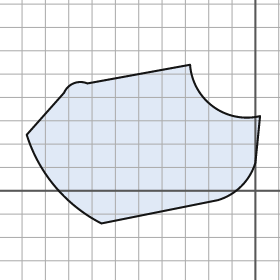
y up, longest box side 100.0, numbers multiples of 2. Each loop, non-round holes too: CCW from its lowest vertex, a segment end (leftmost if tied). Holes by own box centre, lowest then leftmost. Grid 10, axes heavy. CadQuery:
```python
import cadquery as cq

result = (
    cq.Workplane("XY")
    .moveTo(-66.0, -14.0)
    .lineTo(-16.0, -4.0)
    .threePointArc((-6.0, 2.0), (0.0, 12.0))
    .lineTo(2.0, 32.0)
    .threePointArc((-18.0, 36.0), (-28.0, 54.0))
    .lineTo(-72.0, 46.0)
    .threePointArc((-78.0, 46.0), (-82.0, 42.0))
    .lineTo(-98.0, 24.0)
    .threePointArc((-86.0, 2.0), (-66.0, -14.0))
    .close()
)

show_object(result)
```